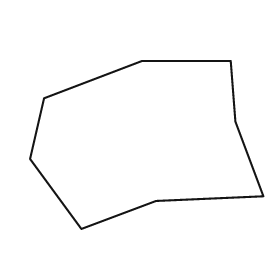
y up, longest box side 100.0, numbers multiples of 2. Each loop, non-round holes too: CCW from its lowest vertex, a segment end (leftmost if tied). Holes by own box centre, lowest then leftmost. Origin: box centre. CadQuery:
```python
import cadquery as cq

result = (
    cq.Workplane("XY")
    .moveTo(-28.0, -36.0)
    .lineTo(4.0, -24.0)
    .lineTo(50.0, -22.0)
    .lineTo(38.0, 10.0)
    .lineTo(36.0, 36.0)
    .lineTo(-2.0, 36.0)
    .lineTo(-44.0, 20.0)
    .lineTo(-50.0, -6.0)
    .close()
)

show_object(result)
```